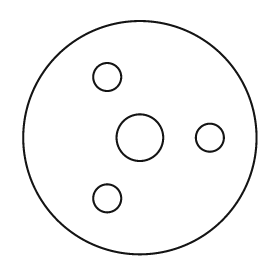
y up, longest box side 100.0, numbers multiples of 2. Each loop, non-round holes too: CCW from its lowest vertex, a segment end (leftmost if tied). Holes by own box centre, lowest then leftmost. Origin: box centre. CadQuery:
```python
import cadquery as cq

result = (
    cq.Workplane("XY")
    .moveTo(0.0, 0.0)
    .circle(50.0)
    .moveTo(-14.0, -26.0)
    .circle(6.0)
    .moveTo(0.0, 0.0)
    .circle(10.0)
    .moveTo(30.0, 0.0)
    .circle(6.0)
    .moveTo(-14.0, 26.0)
    .circle(6.0)
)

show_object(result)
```